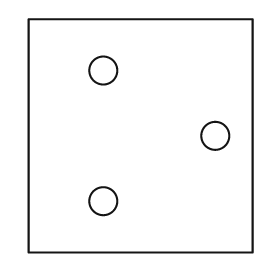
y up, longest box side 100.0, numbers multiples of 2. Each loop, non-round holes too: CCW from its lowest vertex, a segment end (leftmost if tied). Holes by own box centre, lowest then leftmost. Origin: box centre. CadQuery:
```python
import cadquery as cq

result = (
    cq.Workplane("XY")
    .moveTo(-48.0, -50.0)
    .lineTo(48.0, -50.0)
    .lineTo(48.0, 50.0)
    .lineTo(-48.0, 50.0)
    .close()
    .moveTo(-16.0, -28.0)
    .circle(6.0)
    .moveTo(32.0, 0.0)
    .circle(6.0)
    .moveTo(-16.0, 28.0)
    .circle(6.0)
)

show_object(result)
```